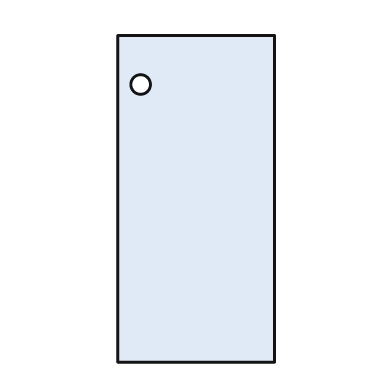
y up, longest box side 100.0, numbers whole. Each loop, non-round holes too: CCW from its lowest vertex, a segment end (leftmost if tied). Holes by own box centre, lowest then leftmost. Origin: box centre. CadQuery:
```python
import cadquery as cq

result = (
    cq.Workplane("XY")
    .moveTo(-24.0, -50.0)
    .lineTo(24.0, -50.0)
    .lineTo(24.0, 50.0)
    .lineTo(-24.0, 50.0)
    .close()
    .moveTo(-17.0, 35.0)
    .circle(3.0)
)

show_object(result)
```